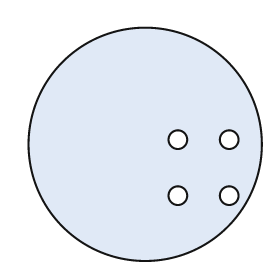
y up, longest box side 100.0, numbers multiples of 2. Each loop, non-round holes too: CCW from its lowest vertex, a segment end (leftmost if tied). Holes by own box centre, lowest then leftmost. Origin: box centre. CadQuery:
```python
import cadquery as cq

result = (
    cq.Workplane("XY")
    .moveTo(0.0, 0.0)
    .circle(50.0)
    .moveTo(14.0, -22.0)
    .circle(4.0)
    .moveTo(36.0, -22.0)
    .circle(4.0)
    .moveTo(14.0, 2.0)
    .circle(4.0)
    .moveTo(36.0, 2.0)
    .circle(4.0)
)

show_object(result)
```